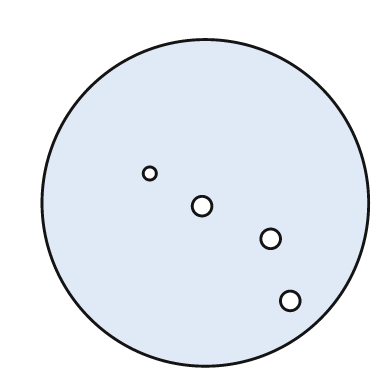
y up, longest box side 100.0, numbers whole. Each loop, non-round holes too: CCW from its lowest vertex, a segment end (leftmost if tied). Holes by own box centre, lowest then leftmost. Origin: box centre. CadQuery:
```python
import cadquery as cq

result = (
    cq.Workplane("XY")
    .moveTo(0.0, 0.0)
    .circle(50.0)
    .moveTo(26.0, -30.0)
    .circle(3.0)
    .moveTo(20.0, -11.0)
    .circle(3.0)
    .moveTo(-1.0, -1.0)
    .circle(3.0)
    .moveTo(-17.0, 9.0)
    .circle(2.0)
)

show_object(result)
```